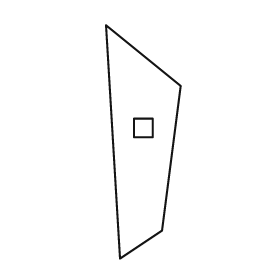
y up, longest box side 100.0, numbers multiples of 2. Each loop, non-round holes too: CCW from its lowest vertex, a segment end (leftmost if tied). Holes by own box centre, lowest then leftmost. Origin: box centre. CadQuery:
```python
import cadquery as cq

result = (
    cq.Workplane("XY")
    .moveTo(-10.0, -50.0)
    .lineTo(8.0, -38.0)
    .lineTo(16.0, 24.0)
    .lineTo(-16.0, 50.0)
    .close()
    .moveTo(-4.0, 2.0)
    .lineTo(4.0, 2.0)
    .lineTo(4.0, 10.0)
    .lineTo(-4.0, 10.0)
    .close()
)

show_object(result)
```